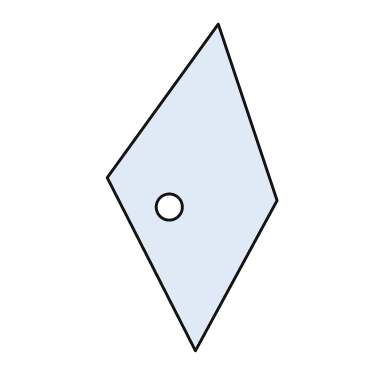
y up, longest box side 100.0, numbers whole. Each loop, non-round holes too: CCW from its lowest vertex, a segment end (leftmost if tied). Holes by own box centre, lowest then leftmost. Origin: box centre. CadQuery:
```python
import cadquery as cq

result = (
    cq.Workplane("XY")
    .moveTo(1.0, -50.0)
    .lineTo(26.0, -4.0)
    .lineTo(8.0, 50.0)
    .lineTo(-26.0, 3.0)
    .close()
    .moveTo(-7.0, -6.0)
    .circle(4.0)
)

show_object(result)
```